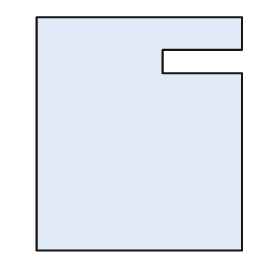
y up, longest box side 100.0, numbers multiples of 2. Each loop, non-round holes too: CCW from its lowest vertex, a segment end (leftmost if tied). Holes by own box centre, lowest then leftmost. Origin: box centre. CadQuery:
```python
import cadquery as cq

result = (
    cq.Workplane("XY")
    .moveTo(-44.0, -50.0)
    .lineTo(44.0, -50.0)
    .lineTo(44.0, 26.0)
    .lineTo(10.0, 26.0)
    .lineTo(10.0, 36.0)
    .lineTo(44.0, 36.0)
    .lineTo(44.0, 50.0)
    .lineTo(-44.0, 50.0)
    .close()
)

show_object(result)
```